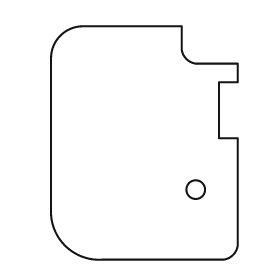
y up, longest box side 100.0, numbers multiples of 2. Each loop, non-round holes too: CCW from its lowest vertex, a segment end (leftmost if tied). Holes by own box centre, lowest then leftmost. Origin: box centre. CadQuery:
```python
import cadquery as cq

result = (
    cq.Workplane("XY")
    .moveTo(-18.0, -50.0)
    .lineTo(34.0, -50.0)
    .threePointArc((38.0, -48.0), (40.0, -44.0))
    .lineTo(40.0, 2.0)
    .lineTo(32.0, 2.0)
    .lineTo(32.0, 26.0)
    .lineTo(40.0, 26.0)
    .lineTo(40.0, 34.0)
    .lineTo(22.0, 34.0)
    .threePointArc((18.0, 36.0), (16.0, 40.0))
    .lineTo(16.0, 50.0)
    .lineTo(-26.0, 50.0)
    .threePointArc((-36.0, 46.0), (-40.0, 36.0))
    .lineTo(-40.0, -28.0)
    .threePointArc((-34.0, -44.0), (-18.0, -50.0))
    .close()
    .moveTo(22.0, -20.0)
    .circle(4.0)
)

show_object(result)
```